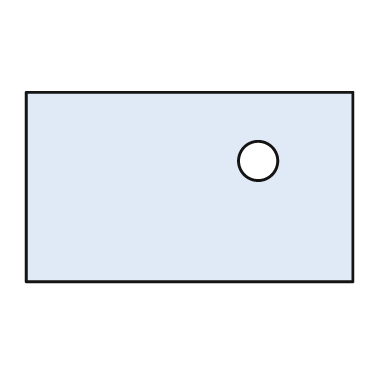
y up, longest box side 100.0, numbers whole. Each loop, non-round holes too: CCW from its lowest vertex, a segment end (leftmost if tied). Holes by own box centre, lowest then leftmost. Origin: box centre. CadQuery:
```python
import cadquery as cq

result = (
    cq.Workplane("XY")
    .moveTo(-50.0, -29.0)
    .lineTo(50.0, -29.0)
    .lineTo(50.0, 29.0)
    .lineTo(-50.0, 29.0)
    .close()
    .moveTo(21.0, 8.0)
    .circle(6.0)
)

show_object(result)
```